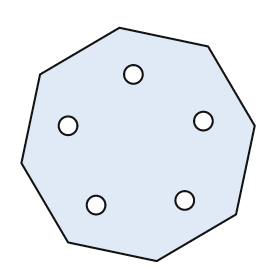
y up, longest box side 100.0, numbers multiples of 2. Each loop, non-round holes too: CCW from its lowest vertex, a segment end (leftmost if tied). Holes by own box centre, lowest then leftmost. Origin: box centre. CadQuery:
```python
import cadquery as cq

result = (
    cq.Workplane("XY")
    .moveTo(8.0, -50.0)
    .lineTo(42.0, -30.0)
    .lineTo(50.0, 8.0)
    .lineTo(30.0, 42.0)
    .lineTo(-8.0, 50.0)
    .lineTo(-42.0, 30.0)
    .lineTo(-50.0, -8.0)
    .lineTo(-30.0, -42.0)
    .close()
    .moveTo(-18.0, -26.0)
    .circle(4.0)
    .moveTo(20.0, -24.0)
    .circle(4.0)
    .moveTo(-30.0, 8.0)
    .circle(4.0)
    .moveTo(28.0, 10.0)
    .circle(4.0)
    .moveTo(-2.0, 30.0)
    .circle(4.0)
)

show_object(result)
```